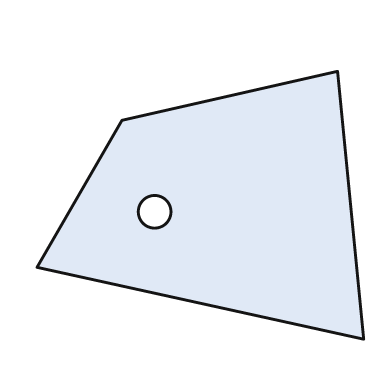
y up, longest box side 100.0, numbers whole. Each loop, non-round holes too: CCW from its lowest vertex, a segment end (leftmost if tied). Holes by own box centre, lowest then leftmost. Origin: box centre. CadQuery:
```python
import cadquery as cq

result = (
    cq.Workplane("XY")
    .moveTo(50.0, -41.0)
    .lineTo(42.0, 41.0)
    .lineTo(-24.0, 26.0)
    .lineTo(-50.0, -19.0)
    .close()
    .moveTo(-14.0, -2.0)
    .circle(5.0)
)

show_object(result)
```